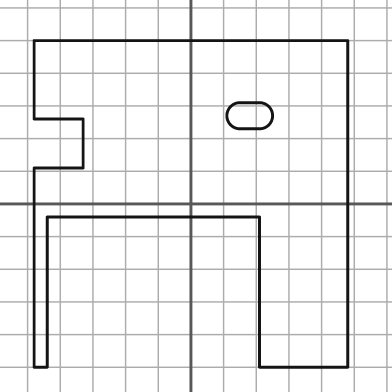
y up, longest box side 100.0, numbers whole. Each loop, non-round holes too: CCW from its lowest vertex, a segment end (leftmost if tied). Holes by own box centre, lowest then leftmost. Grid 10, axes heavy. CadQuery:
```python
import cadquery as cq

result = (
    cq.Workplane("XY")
    .moveTo(-48.0, -50.0)
    .lineTo(-44.0, -50.0)
    .lineTo(-44.0, -4.0)
    .lineTo(21.0, -4.0)
    .lineTo(21.0, -50.0)
    .lineTo(48.0, -50.0)
    .lineTo(48.0, 50.0)
    .lineTo(-48.0, 50.0)
    .lineTo(-48.0, 26.0)
    .lineTo(-33.0, 26.0)
    .lineTo(-33.0, 11.0)
    .lineTo(-48.0, 11.0)
    .close()
    .moveTo(15.0, 23.0)
    .lineTo(21.0, 23.0)
    .threePointArc((25.0, 27.0), (21.0, 31.0))
    .lineTo(15.0, 31.0)
    .threePointArc((11.0, 27.0), (15.0, 23.0))
    .close()
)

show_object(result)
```